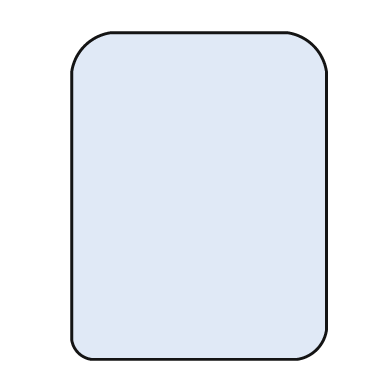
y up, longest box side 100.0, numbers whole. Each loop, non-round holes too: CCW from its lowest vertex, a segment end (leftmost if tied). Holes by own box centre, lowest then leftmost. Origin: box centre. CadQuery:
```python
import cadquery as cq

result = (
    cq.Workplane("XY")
    .moveTo(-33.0, -50.0)
    .lineTo(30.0, -50.0)
    .threePointArc((36.0, -47.0), (39.0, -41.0))
    .lineTo(39.0, 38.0)
    .threePointArc((35.0, 46.0), (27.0, 50.0))
    .lineTo(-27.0, 50.0)
    .threePointArc((-35.0, 46.0), (-39.0, 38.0))
    .lineTo(-39.0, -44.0)
    .threePointArc((-37.0, -48.0), (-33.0, -50.0))
    .close()
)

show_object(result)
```